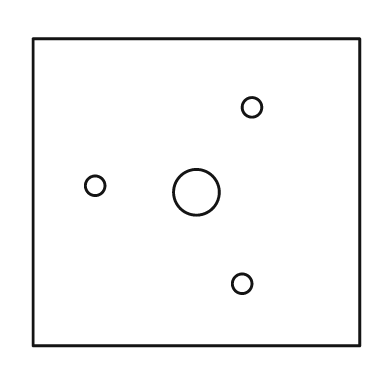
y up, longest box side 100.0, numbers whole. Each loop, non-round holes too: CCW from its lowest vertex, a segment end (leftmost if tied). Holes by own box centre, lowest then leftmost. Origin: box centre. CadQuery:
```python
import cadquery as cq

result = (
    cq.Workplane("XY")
    .moveTo(-50.0, -47.0)
    .lineTo(50.0, -47.0)
    .lineTo(50.0, 47.0)
    .lineTo(-50.0, 47.0)
    .close()
    .moveTo(14.0, -28.0)
    .circle(3.0)
    .moveTo(0.0, 0.0)
    .circle(7.0)
    .moveTo(-31.0, 2.0)
    .circle(3.0)
    .moveTo(17.0, 26.0)
    .circle(3.0)
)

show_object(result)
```